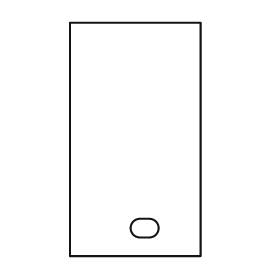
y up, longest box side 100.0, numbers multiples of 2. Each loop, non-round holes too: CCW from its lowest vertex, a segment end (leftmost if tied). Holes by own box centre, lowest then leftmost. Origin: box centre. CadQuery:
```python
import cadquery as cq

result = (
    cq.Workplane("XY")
    .moveTo(-28.0, -50.0)
    .lineTo(28.0, -50.0)
    .lineTo(28.0, 50.0)
    .lineTo(-28.0, 50.0)
    .close()
    .moveTo(2.0, -42.0)
    .lineTo(6.0, -42.0)
    .threePointArc((10.0, -38.0), (6.0, -34.0))
    .lineTo(2.0, -34.0)
    .threePointArc((-2.0, -38.0), (2.0, -42.0))
    .close()
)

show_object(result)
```